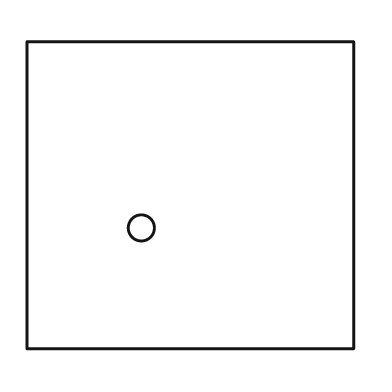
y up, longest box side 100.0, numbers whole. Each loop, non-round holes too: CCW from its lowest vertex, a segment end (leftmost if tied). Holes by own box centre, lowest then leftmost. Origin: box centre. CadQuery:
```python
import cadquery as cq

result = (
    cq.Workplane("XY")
    .moveTo(-50.0, -47.0)
    .lineTo(50.0, -47.0)
    .lineTo(50.0, 47.0)
    .lineTo(-50.0, 47.0)
    .close()
    .moveTo(-15.0, -10.0)
    .circle(4.0)
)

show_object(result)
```